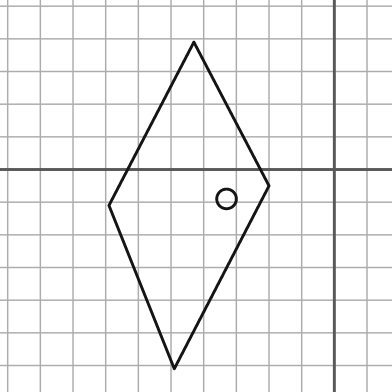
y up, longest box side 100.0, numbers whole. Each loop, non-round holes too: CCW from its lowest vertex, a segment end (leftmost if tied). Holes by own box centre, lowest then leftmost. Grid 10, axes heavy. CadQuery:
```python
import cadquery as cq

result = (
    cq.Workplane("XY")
    .moveTo(-49.0, -61.0)
    .lineTo(-20.0, -5.0)
    .lineTo(-43.0, 39.0)
    .lineTo(-69.0, -11.0)
    .close()
    .moveTo(-33.0, -9.0)
    .circle(3.0)
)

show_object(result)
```